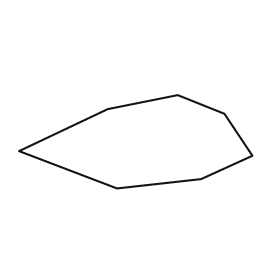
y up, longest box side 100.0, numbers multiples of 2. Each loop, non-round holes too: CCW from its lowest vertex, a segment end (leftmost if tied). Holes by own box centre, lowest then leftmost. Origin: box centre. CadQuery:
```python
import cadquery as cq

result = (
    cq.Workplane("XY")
    .moveTo(-8.0, -20.0)
    .lineTo(28.0, -16.0)
    .lineTo(50.0, -6.0)
    .lineTo(38.0, 12.0)
    .lineTo(18.0, 20.0)
    .lineTo(-12.0, 14.0)
    .lineTo(-50.0, -4.0)
    .close()
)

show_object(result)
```